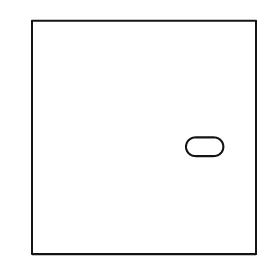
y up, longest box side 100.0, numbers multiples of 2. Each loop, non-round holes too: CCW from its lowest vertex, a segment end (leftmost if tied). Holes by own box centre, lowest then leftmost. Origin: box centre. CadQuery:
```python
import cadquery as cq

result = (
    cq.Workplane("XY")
    .moveTo(-48.0, -50.0)
    .lineTo(48.0, -50.0)
    .lineTo(48.0, 50.0)
    .lineTo(-48.0, 50.0)
    .close()
    .moveTo(22.0, -8.0)
    .lineTo(30.0, -8.0)
    .threePointArc((34.0, -4.0), (30.0, 0.0))
    .lineTo(22.0, 0.0)
    .threePointArc((18.0, -4.0), (22.0, -8.0))
    .close()
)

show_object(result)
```